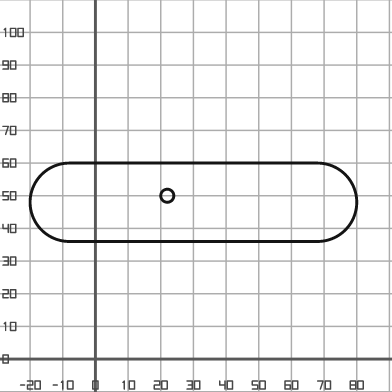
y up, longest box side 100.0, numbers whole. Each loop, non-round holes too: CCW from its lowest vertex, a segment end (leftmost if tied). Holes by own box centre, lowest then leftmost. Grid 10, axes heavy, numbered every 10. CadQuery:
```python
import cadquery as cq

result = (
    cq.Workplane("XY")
    .moveTo(-8.0, 36.0)
    .lineTo(68.0, 36.0)
    .threePointArc((80.0, 48.0), (68.0, 60.0))
    .lineTo(-8.0, 60.0)
    .threePointArc((-20.0, 48.0), (-8.0, 36.0))
    .close()
    .moveTo(22.0, 50.0)
    .circle(2.0)
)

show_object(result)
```